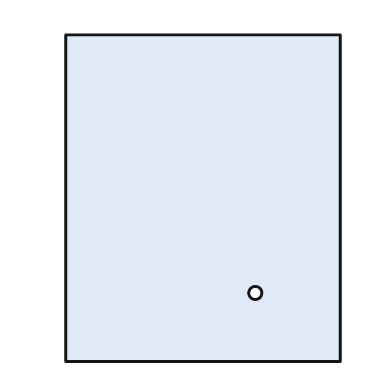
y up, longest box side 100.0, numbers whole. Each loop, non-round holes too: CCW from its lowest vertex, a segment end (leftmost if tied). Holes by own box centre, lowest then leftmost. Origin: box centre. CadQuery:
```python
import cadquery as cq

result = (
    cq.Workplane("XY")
    .moveTo(-42.0, -50.0)
    .lineTo(42.0, -50.0)
    .lineTo(42.0, 50.0)
    .lineTo(-42.0, 50.0)
    .close()
    .moveTo(16.0, -29.0)
    .circle(2.0)
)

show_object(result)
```